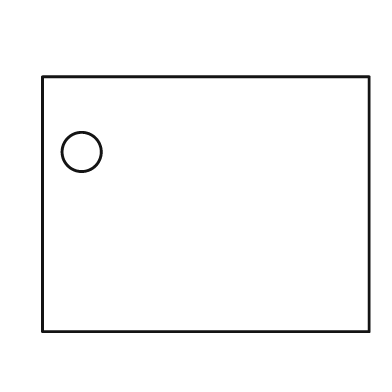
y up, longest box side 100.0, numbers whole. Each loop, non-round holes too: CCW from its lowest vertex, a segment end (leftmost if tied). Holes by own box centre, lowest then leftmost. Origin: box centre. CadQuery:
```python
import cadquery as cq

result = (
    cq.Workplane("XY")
    .moveTo(-50.0, -39.0)
    .lineTo(50.0, -39.0)
    .lineTo(50.0, 39.0)
    .lineTo(-50.0, 39.0)
    .close()
    .moveTo(-38.0, 16.0)
    .circle(6.0)
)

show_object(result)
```